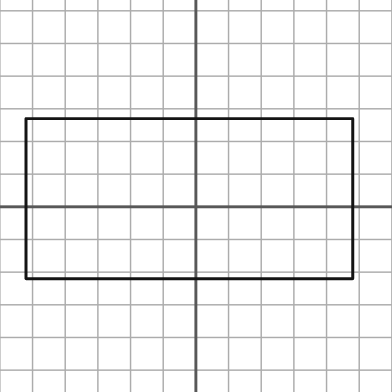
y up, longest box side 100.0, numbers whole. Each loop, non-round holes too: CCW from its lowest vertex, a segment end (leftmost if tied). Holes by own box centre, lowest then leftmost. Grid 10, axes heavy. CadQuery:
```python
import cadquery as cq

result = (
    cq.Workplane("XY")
    .moveTo(-52.0, -22.0)
    .lineTo(48.0, -22.0)
    .lineTo(48.0, 27.0)
    .lineTo(-52.0, 27.0)
    .close()
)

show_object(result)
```